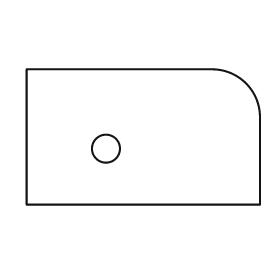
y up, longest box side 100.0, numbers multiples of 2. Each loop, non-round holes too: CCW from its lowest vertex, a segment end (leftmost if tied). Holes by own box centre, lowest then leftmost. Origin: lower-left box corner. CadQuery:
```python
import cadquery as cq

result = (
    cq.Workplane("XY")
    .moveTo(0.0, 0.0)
    .lineTo(100.0, 0.0)
    .lineTo(100.0, 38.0)
    .threePointArc((94.0, 52.0), (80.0, 58.0))
    .lineTo(0.0, 58.0)
    .close()
    .moveTo(34.0, 24.0)
    .circle(6.0)
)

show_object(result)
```